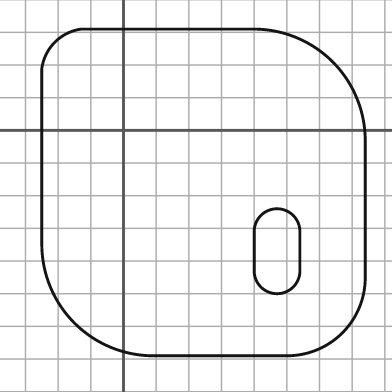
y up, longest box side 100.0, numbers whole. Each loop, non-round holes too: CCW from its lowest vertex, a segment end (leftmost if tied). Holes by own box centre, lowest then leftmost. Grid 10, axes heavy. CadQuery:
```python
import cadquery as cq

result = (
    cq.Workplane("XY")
    .moveTo(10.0, -69.0)
    .lineTo(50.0, -69.0)
    .threePointArc((67.0, -62.0), (74.0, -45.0))
    .lineTo(74.0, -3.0)
    .threePointArc((64.0, 21.0), (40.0, 31.0))
    .lineTo(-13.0, 31.0)
    .threePointArc((-21.0, 27.0), (-25.0, 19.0))
    .lineTo(-25.0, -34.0)
    .threePointArc((-15.0, -59.0), (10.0, -69.0))
    .close()
    .moveTo(40.0, -43.0)
    .threePointArc((47.0, -50.0), (54.0, -43.0))
    .lineTo(54.0, -31.0)
    .threePointArc((47.0, -24.0), (40.0, -31.0))
    .close()
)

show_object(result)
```